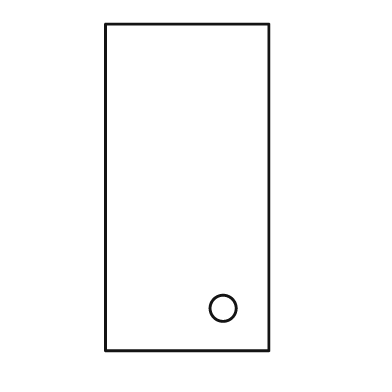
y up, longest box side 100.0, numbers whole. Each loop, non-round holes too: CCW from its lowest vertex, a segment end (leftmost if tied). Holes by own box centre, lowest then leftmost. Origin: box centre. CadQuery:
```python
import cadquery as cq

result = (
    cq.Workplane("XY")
    .moveTo(-25.0, -50.0)
    .lineTo(25.0, -50.0)
    .lineTo(25.0, 50.0)
    .lineTo(-25.0, 50.0)
    .close()
    .moveTo(11.0, -37.0)
    .circle(4.0)
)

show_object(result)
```